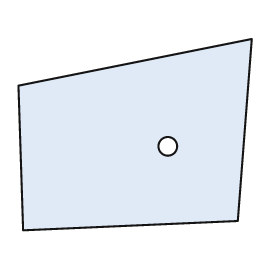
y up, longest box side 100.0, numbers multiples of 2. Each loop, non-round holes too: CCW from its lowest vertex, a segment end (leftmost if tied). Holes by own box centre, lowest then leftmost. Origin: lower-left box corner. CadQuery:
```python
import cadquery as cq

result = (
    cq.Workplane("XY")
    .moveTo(2.0, 0.0)
    .lineTo(94.0, 4.0)
    .lineTo(100.0, 82.0)
    .lineTo(0.0, 62.0)
    .close()
    .moveTo(64.0, 36.0)
    .circle(4.0)
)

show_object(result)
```